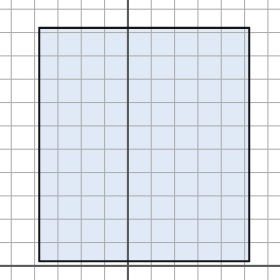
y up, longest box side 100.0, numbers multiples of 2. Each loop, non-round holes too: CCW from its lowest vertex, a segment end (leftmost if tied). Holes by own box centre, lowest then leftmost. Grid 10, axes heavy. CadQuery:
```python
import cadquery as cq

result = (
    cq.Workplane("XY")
    .moveTo(-38.0, 2.0)
    .lineTo(52.0, 2.0)
    .lineTo(52.0, 102.0)
    .lineTo(-38.0, 102.0)
    .close()
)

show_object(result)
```